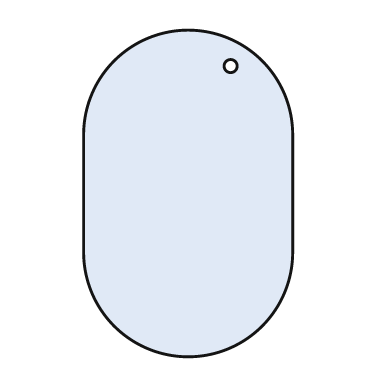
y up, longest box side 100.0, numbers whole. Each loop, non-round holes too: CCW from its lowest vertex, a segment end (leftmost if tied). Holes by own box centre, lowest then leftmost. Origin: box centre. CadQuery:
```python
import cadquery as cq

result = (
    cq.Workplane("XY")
    .moveTo(-32.0, -18.0)
    .threePointArc((0.0, -50.0), (32.0, -18.0))
    .lineTo(32.0, 18.0)
    .threePointArc((0.0, 50.0), (-32.0, 18.0))
    .close()
    .moveTo(13.0, 39.0)
    .circle(2.0)
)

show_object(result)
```